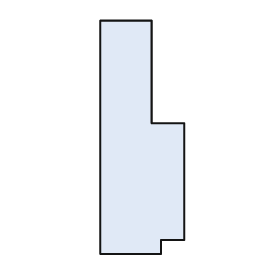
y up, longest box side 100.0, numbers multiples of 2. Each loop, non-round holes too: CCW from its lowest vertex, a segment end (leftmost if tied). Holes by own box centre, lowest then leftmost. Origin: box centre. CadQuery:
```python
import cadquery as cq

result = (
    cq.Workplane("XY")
    .moveTo(-18.0, -50.0)
    .lineTo(8.0, -50.0)
    .lineTo(8.0, -44.0)
    .lineTo(18.0, -44.0)
    .lineTo(18.0, 6.0)
    .lineTo(4.0, 6.0)
    .lineTo(4.0, 50.0)
    .lineTo(-18.0, 50.0)
    .close()
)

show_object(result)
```